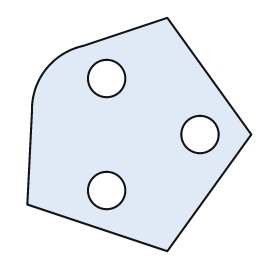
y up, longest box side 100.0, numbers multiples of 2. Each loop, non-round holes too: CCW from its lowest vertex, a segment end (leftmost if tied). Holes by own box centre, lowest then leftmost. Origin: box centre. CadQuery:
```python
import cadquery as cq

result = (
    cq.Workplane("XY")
    .moveTo(12.0, -50.0)
    .lineTo(48.0, 0.0)
    .lineTo(12.0, 50.0)
    .lineTo(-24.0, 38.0)
    .threePointArc((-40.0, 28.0), (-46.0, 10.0))
    .lineTo(-48.0, -30.0)
    .close()
    .moveTo(-14.0, -24.0)
    .circle(8.0)
    .moveTo(26.0, 0.0)
    .circle(8.0)
    .moveTo(-14.0, 24.0)
    .circle(8.0)
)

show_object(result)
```